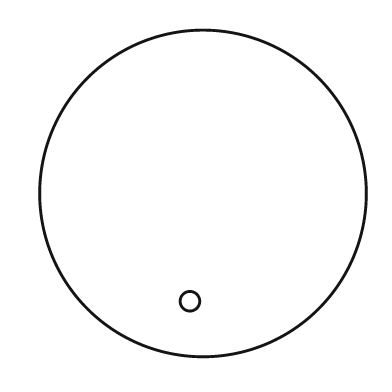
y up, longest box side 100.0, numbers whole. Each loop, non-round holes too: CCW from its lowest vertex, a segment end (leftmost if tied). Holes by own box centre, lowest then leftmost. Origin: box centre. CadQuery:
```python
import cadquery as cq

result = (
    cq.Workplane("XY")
    .moveTo(0.0, 0.0)
    .circle(50.0)
    .moveTo(-4.0, -33.0)
    .circle(3.0)
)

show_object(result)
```